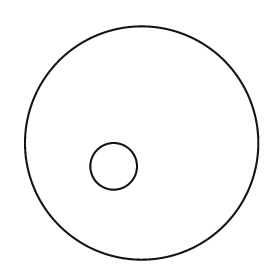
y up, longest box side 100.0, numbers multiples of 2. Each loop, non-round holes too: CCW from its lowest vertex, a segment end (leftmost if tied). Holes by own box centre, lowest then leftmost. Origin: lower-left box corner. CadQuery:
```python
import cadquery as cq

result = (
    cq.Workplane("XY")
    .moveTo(50.0, 50.0)
    .circle(50.0)
    .moveTo(38.0, 40.0)
    .circle(10.0)
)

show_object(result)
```